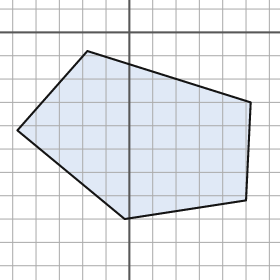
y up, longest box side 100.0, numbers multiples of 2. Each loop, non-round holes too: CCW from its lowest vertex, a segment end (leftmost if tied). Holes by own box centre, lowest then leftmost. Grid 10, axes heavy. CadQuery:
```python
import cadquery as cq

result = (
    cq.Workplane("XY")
    .moveTo(-2.0, -80.0)
    .lineTo(50.0, -72.0)
    .lineTo(52.0, -30.0)
    .lineTo(-18.0, -8.0)
    .lineTo(-48.0, -42.0)
    .close()
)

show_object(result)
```